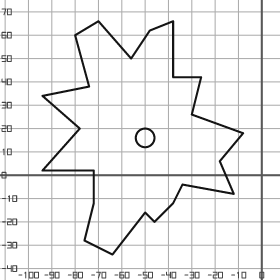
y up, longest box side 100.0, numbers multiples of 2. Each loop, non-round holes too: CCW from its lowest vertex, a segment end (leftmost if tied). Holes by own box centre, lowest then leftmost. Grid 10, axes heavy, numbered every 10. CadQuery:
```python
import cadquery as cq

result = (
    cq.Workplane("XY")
    .moveTo(-64.0, -34.0)
    .lineTo(-50.0, -16.0)
    .lineTo(-46.0, -20.0)
    .lineTo(-38.0, -12.0)
    .lineTo(-34.0, -4.0)
    .lineTo(-12.0, -8.0)
    .lineTo(-18.0, 6.0)
    .lineTo(-8.0, 18.0)
    .lineTo(-30.0, 26.0)
    .lineTo(-26.0, 42.0)
    .lineTo(-38.0, 42.0)
    .lineTo(-38.0, 66.0)
    .lineTo(-48.0, 62.0)
    .lineTo(-56.0, 50.0)
    .lineTo(-70.0, 66.0)
    .lineTo(-80.0, 60.0)
    .lineTo(-74.0, 38.0)
    .lineTo(-94.0, 34.0)
    .lineTo(-78.0, 20.0)
    .lineTo(-94.0, 2.0)
    .lineTo(-72.0, 2.0)
    .lineTo(-72.0, -12.0)
    .lineTo(-76.0, -28.0)
    .close()
    .moveTo(-50.0, 16.0)
    .circle(4.0)
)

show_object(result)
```